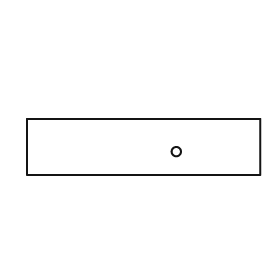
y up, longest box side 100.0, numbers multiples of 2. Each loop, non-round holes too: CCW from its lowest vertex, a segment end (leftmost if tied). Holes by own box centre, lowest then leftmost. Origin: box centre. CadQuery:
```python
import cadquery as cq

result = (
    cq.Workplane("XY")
    .moveTo(-50.0, -12.0)
    .lineTo(50.0, -12.0)
    .lineTo(50.0, 12.0)
    .lineTo(-50.0, 12.0)
    .close()
    .moveTo(14.0, -2.0)
    .circle(2.0)
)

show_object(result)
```